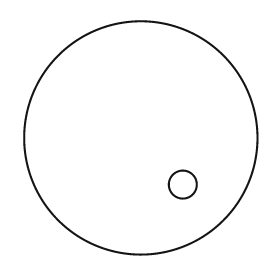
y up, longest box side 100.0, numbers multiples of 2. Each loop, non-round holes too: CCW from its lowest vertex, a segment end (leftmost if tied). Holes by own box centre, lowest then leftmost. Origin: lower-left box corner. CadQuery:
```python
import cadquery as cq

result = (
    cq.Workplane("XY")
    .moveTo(50.0, 50.0)
    .circle(50.0)
    .moveTo(68.0, 30.0)
    .circle(6.0)
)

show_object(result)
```